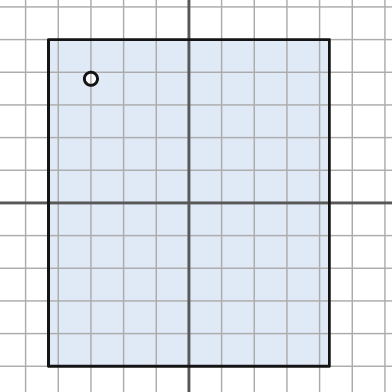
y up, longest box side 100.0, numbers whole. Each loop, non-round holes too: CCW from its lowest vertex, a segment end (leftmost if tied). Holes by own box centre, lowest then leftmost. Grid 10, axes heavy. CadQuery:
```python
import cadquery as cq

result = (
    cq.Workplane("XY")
    .moveTo(-43.0, -50.0)
    .lineTo(43.0, -50.0)
    .lineTo(43.0, 50.0)
    .lineTo(-43.0, 50.0)
    .close()
    .moveTo(-30.0, 38.0)
    .circle(2.0)
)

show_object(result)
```